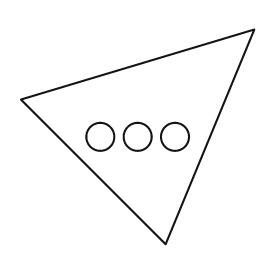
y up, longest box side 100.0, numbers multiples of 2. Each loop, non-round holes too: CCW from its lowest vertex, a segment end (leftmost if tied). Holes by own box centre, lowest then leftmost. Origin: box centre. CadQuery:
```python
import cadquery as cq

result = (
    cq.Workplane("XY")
    .moveTo(12.0, -46.0)
    .lineTo(50.0, 46.0)
    .lineTo(-50.0, 16.0)
    .close()
    .moveTo(-16.0, 0.0)
    .circle(6.0)
    .moveTo(0.0, 0.0)
    .circle(6.0)
    .moveTo(16.0, 0.0)
    .circle(6.0)
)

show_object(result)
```